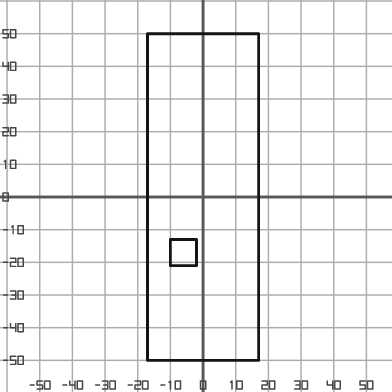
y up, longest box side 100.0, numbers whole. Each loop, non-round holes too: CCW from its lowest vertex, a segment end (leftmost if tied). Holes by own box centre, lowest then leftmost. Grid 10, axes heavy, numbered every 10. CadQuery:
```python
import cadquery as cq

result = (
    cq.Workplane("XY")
    .moveTo(-17.0, -50.0)
    .lineTo(17.0, -50.0)
    .lineTo(17.0, 50.0)
    .lineTo(-17.0, 50.0)
    .close()
    .moveTo(-10.0, -21.0)
    .lineTo(-2.0, -21.0)
    .lineTo(-2.0, -13.0)
    .lineTo(-10.0, -13.0)
    .close()
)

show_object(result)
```